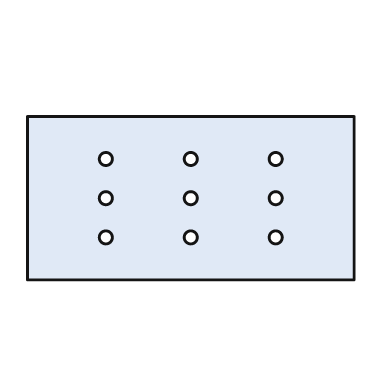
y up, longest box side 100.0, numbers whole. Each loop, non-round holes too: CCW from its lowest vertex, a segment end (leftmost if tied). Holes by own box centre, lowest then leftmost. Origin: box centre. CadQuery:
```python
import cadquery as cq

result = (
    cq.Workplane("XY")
    .moveTo(-50.0, -25.0)
    .lineTo(50.0, -25.0)
    .lineTo(50.0, 25.0)
    .lineTo(-50.0, 25.0)
    .close()
    .moveTo(-26.0, -12.0)
    .circle(2.0)
    .moveTo(0.0, -12.0)
    .circle(2.0)
    .moveTo(26.0, -12.0)
    .circle(2.0)
    .moveTo(-26.0, 0.0)
    .circle(2.0)
    .moveTo(0.0, 0.0)
    .circle(2.0)
    .moveTo(26.0, 0.0)
    .circle(2.0)
    .moveTo(-26.0, 12.0)
    .circle(2.0)
    .moveTo(0.0, 12.0)
    .circle(2.0)
    .moveTo(26.0, 12.0)
    .circle(2.0)
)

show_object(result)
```